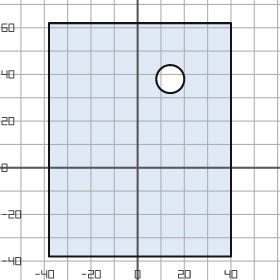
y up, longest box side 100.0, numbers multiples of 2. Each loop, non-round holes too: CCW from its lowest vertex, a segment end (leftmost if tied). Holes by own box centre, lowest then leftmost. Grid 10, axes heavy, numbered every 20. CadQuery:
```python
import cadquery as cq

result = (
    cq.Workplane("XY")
    .moveTo(-38.0, -38.0)
    .lineTo(40.0, -38.0)
    .lineTo(40.0, 62.0)
    .lineTo(-38.0, 62.0)
    .close()
    .moveTo(14.0, 38.0)
    .circle(6.0)
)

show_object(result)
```